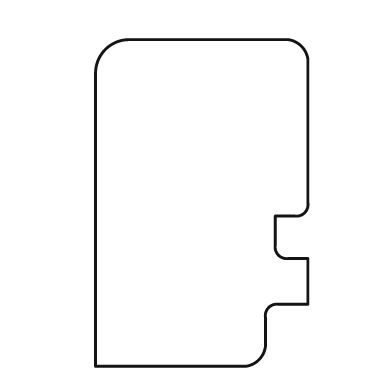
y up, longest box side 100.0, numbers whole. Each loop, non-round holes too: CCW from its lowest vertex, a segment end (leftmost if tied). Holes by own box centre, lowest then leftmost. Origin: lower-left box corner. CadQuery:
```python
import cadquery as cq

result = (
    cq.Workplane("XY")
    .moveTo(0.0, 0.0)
    .lineTo(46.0, 0.0)
    .threePointArc((50.0, 2.0), (52.0, 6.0))
    .lineTo(52.0, 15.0)
    .threePointArc((53.0, 18.0), (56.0, 19.0))
    .lineTo(65.0, 19.0)
    .lineTo(65.0, 33.0)
    .lineTo(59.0, 33.0)
    .threePointArc((56.0, 34.0), (55.0, 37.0))
    .lineTo(55.0, 46.0)
    .lineTo(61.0, 46.0)
    .threePointArc((64.0, 47.0), (65.0, 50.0))
    .lineTo(65.0, 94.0)
    .threePointArc((63.0, 98.0), (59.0, 100.0))
    .lineTo(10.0, 100.0)
    .threePointArc((3.0, 97.0), (0.0, 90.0))
    .close()
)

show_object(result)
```